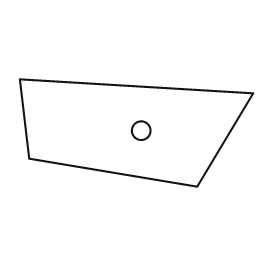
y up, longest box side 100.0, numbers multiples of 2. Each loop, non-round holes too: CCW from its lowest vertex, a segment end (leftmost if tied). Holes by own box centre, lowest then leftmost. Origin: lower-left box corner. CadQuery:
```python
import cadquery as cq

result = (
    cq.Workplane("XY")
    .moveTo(76.0, 0.0)
    .lineTo(100.0, 40.0)
    .lineTo(0.0, 46.0)
    .lineTo(4.0, 12.0)
    .close()
    .moveTo(52.0, 24.0)
    .circle(4.0)
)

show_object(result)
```